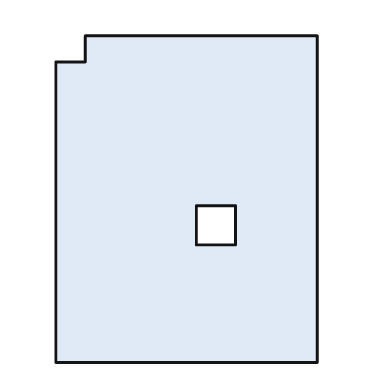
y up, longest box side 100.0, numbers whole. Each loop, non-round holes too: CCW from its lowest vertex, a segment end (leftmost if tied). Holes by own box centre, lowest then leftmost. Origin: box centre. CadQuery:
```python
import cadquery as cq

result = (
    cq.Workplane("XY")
    .moveTo(-40.0, -50.0)
    .lineTo(40.0, -50.0)
    .lineTo(40.0, 50.0)
    .lineTo(-31.0, 50.0)
    .lineTo(-31.0, 42.0)
    .lineTo(-40.0, 42.0)
    .close()
    .moveTo(3.0, -14.0)
    .lineTo(15.0, -14.0)
    .lineTo(15.0, -2.0)
    .lineTo(3.0, -2.0)
    .close()
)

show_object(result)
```